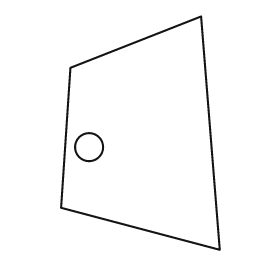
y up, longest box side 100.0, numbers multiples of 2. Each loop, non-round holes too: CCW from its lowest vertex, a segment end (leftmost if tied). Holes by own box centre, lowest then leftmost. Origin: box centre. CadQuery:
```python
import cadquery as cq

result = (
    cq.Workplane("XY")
    .moveTo(34.0, -50.0)
    .lineTo(26.0, 50.0)
    .lineTo(-30.0, 28.0)
    .lineTo(-34.0, -32.0)
    .close()
    .moveTo(-22.0, -6.0)
    .circle(6.0)
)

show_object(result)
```